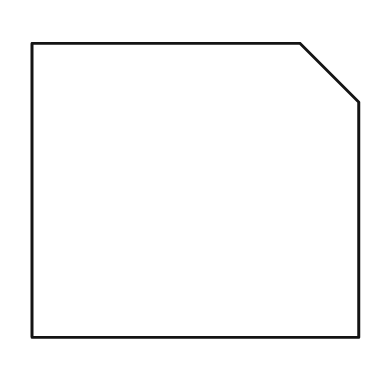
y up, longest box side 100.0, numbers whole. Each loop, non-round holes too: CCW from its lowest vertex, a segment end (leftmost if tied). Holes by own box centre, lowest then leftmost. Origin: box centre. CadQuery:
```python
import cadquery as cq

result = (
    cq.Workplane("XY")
    .moveTo(-50.0, -45.0)
    .lineTo(50.0, -45.0)
    .lineTo(50.0, 27.0)
    .lineTo(32.0, 45.0)
    .lineTo(-50.0, 45.0)
    .close()
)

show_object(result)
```